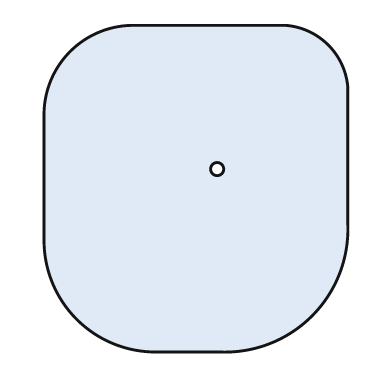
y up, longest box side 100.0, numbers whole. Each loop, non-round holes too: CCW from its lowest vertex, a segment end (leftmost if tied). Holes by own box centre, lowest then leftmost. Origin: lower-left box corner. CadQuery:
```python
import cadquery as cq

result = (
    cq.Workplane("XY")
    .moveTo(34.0, 0.0)
    .lineTo(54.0, 0.0)
    .threePointArc((82.0, 11.0), (93.0, 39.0))
    .lineTo(93.0, 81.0)
    .threePointArc((87.0, 94.0), (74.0, 100.0))
    .lineTo(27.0, 100.0)
    .threePointArc((8.0, 92.0), (0.0, 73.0))
    .lineTo(0.0, 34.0)
    .threePointArc((10.0, 10.0), (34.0, 0.0))
    .close()
    .moveTo(53.0, 56.0)
    .circle(2.0)
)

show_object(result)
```